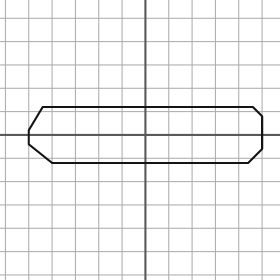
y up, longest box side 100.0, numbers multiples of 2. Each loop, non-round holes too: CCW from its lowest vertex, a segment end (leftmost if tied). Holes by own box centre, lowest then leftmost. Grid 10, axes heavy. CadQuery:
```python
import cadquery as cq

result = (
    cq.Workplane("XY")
    .moveTo(-40.0, -12.0)
    .lineTo(44.0, -12.0)
    .lineTo(50.0, -6.0)
    .lineTo(50.0, 8.0)
    .lineTo(46.0, 12.0)
    .lineTo(-44.0, 12.0)
    .lineTo(-50.0, 2.0)
    .lineTo(-50.0, -4.0)
    .close()
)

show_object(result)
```